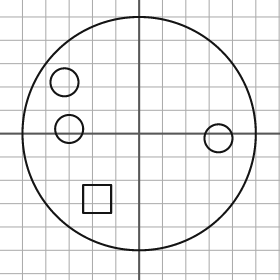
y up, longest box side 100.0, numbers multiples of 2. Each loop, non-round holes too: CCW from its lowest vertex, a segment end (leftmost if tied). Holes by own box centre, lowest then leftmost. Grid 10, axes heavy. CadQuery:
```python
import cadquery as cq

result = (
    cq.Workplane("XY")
    .moveTo(0.0, 0.0)
    .circle(50.0)
    .moveTo(-24.0, -34.0)
    .lineTo(-12.0, -34.0)
    .lineTo(-12.0, -22.0)
    .lineTo(-24.0, -22.0)
    .close()
    .moveTo(34.0, -2.0)
    .circle(6.0)
    .moveTo(-30.0, 2.0)
    .circle(6.0)
    .moveTo(-32.0, 22.0)
    .circle(6.0)
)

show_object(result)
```